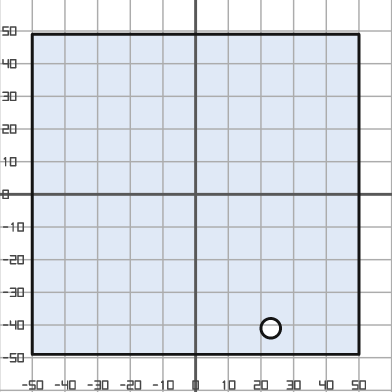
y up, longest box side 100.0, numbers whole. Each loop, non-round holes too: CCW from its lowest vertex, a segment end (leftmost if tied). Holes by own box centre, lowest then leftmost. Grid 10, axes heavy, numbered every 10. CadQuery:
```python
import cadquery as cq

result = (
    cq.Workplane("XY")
    .moveTo(-50.0, -49.0)
    .lineTo(50.0, -49.0)
    .lineTo(50.0, 49.0)
    .lineTo(-50.0, 49.0)
    .close()
    .moveTo(23.0, -41.0)
    .circle(3.0)
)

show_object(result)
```